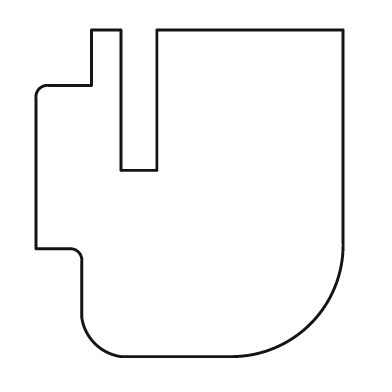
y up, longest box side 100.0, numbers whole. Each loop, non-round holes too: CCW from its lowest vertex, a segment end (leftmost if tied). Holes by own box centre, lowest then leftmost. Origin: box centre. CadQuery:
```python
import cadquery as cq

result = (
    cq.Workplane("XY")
    .moveTo(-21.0, -50.0)
    .lineTo(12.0, -50.0)
    .threePointArc((37.0, -40.0), (47.0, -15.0))
    .lineTo(47.0, 50.0)
    .lineTo(-10.0, 50.0)
    .lineTo(-10.0, 7.0)
    .lineTo(-21.0, 7.0)
    .lineTo(-21.0, 50.0)
    .lineTo(-30.0, 50.0)
    .lineTo(-30.0, 33.0)
    .lineTo(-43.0, 33.0)
    .threePointArc((-46.0, 32.0), (-47.0, 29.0))
    .lineTo(-47.0, -17.0)
    .lineTo(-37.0, -17.0)
    .threePointArc((-34.0, -18.0), (-33.0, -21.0))
    .lineTo(-33.0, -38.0)
    .threePointArc((-29.0, -46.0), (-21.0, -50.0))
    .close()
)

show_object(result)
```